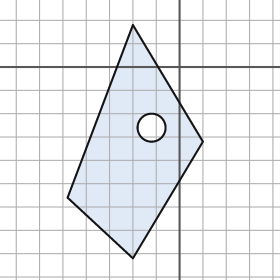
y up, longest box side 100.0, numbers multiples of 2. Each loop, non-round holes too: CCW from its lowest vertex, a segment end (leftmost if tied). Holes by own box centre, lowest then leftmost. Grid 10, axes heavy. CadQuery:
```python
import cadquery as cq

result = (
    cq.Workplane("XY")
    .moveTo(-20.0, -82.0)
    .lineTo(10.0, -32.0)
    .lineTo(-20.0, 18.0)
    .lineTo(-48.0, -56.0)
    .close()
    .moveTo(-12.0, -26.0)
    .circle(6.0)
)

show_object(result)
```